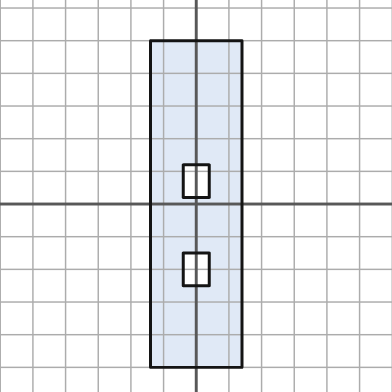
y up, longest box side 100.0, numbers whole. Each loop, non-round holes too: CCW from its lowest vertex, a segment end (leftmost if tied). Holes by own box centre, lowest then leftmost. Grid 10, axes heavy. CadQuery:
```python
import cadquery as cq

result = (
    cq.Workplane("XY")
    .moveTo(-14.0, -50.0)
    .lineTo(14.0, -50.0)
    .lineTo(14.0, 50.0)
    .lineTo(-14.0, 50.0)
    .close()
    .moveTo(-4.0, -25.0)
    .lineTo(4.0, -25.0)
    .lineTo(4.0, -15.0)
    .lineTo(-4.0, -15.0)
    .close()
    .moveTo(-4.0, 2.0)
    .lineTo(4.0, 2.0)
    .lineTo(4.0, 12.0)
    .lineTo(-4.0, 12.0)
    .close()
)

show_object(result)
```